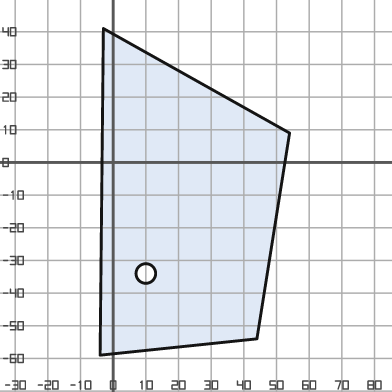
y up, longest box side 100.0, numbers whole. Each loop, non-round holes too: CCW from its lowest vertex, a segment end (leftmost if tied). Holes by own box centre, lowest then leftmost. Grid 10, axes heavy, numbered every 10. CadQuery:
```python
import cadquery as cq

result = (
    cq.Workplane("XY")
    .moveTo(-4.0, -59.0)
    .lineTo(44.0, -54.0)
    .lineTo(54.0, 9.0)
    .lineTo(-3.0, 41.0)
    .close()
    .moveTo(10.0, -34.0)
    .circle(3.0)
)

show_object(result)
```